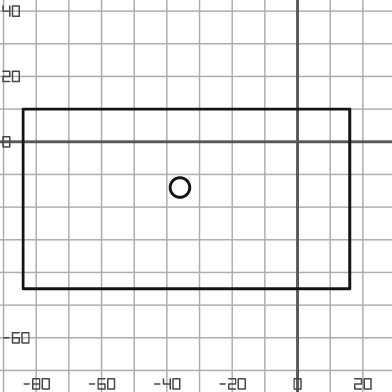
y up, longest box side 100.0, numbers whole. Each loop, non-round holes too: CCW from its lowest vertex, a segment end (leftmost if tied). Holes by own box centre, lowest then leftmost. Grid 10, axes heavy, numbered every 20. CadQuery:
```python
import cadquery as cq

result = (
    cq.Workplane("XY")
    .moveTo(-84.0, -45.0)
    .lineTo(16.0, -45.0)
    .lineTo(16.0, 10.0)
    .lineTo(-84.0, 10.0)
    .close()
    .moveTo(-36.0, -14.0)
    .circle(3.0)
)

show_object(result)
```